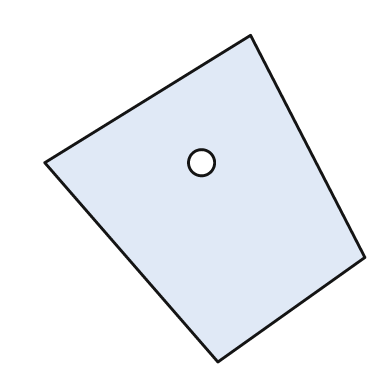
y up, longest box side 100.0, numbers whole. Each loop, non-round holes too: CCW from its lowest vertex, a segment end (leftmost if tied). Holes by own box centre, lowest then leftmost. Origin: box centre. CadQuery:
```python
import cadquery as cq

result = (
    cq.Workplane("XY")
    .moveTo(4.0, -50.0)
    .lineTo(49.0, -18.0)
    .lineTo(14.0, 50.0)
    .lineTo(-49.0, 11.0)
    .close()
    .moveTo(-1.0, 11.0)
    .circle(4.0)
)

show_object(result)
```